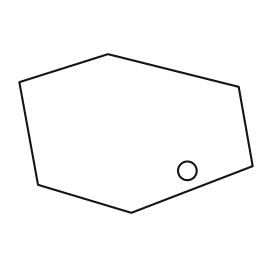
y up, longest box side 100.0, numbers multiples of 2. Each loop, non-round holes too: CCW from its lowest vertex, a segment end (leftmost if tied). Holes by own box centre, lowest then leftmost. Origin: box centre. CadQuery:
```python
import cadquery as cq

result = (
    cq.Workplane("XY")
    .moveTo(-2.0, -34.0)
    .lineTo(50.0, -14.0)
    .lineTo(44.0, 20.0)
    .lineTo(-12.0, 34.0)
    .lineTo(-50.0, 22.0)
    .lineTo(-42.0, -22.0)
    .close()
    .moveTo(22.0, -16.0)
    .circle(4.0)
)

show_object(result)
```